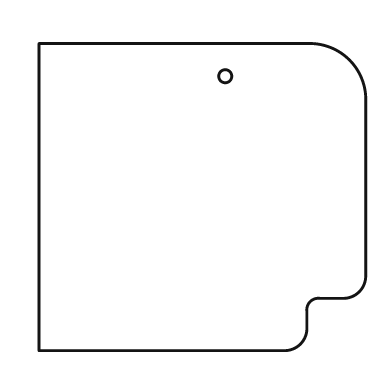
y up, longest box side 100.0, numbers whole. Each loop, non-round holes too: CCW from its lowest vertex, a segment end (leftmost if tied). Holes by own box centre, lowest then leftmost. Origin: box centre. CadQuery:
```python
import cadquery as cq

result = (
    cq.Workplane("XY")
    .moveTo(-50.0, -47.0)
    .lineTo(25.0, -47.0)
    .threePointArc((30.0, -45.0), (32.0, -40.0))
    .lineTo(32.0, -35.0)
    .threePointArc((33.0, -32.0), (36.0, -31.0))
    .lineTo(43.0, -31.0)
    .threePointArc((48.0, -29.0), (50.0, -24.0))
    .lineTo(50.0, 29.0)
    .threePointArc((45.0, 42.0), (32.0, 47.0))
    .lineTo(-50.0, 47.0)
    .close()
    .moveTo(7.0, 37.0)
    .circle(2.0)
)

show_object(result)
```